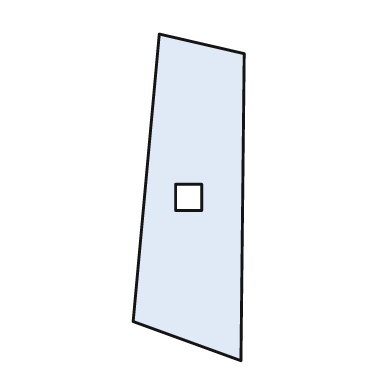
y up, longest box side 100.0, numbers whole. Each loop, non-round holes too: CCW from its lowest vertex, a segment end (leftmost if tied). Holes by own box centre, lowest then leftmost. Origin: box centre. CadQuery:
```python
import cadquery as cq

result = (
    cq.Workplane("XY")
    .moveTo(16.0, -50.0)
    .lineTo(17.0, 44.0)
    .lineTo(-9.0, 50.0)
    .lineTo(-17.0, -38.0)
    .close()
    .moveTo(-4.0, -4.0)
    .lineTo(4.0, -4.0)
    .lineTo(4.0, 4.0)
    .lineTo(-4.0, 4.0)
    .close()
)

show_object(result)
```